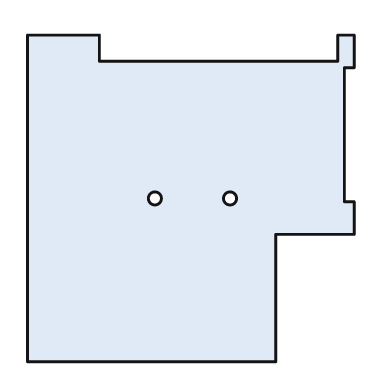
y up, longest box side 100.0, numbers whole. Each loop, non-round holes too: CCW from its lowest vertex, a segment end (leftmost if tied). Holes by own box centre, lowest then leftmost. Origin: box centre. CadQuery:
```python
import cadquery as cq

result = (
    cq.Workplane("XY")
    .moveTo(-50.0, -50.0)
    .lineTo(26.0, -50.0)
    .lineTo(26.0, -11.0)
    .lineTo(50.0, -11.0)
    .lineTo(50.0, -1.0)
    .lineTo(47.0, -1.0)
    .lineTo(47.0, 40.0)
    .lineTo(50.0, 40.0)
    .lineTo(50.0, 50.0)
    .lineTo(45.0, 50.0)
    .lineTo(45.0, 42.0)
    .lineTo(-28.0, 42.0)
    .lineTo(-28.0, 50.0)
    .lineTo(-50.0, 50.0)
    .close()
    .moveTo(-11.0, 0.0)
    .circle(2.0)
    .moveTo(12.0, 0.0)
    .circle(2.0)
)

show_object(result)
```